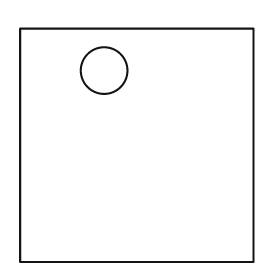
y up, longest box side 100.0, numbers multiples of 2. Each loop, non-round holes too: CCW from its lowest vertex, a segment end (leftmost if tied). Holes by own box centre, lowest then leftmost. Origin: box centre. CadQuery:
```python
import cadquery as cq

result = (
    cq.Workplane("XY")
    .moveTo(-50.0, -50.0)
    .lineTo(50.0, -50.0)
    .lineTo(50.0, 50.0)
    .lineTo(-50.0, 50.0)
    .close()
    .moveTo(-14.0, 32.0)
    .circle(10.0)
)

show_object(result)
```